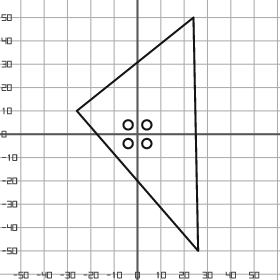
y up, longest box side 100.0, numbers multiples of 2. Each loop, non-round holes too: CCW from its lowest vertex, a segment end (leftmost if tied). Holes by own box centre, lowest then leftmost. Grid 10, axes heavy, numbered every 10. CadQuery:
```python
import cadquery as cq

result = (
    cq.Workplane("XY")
    .moveTo(26.0, -50.0)
    .lineTo(24.0, 50.0)
    .lineTo(-26.0, 10.0)
    .close()
    .moveTo(-4.0, -4.0)
    .circle(2.0)
    .moveTo(4.0, -4.0)
    .circle(2.0)
    .moveTo(-4.0, 4.0)
    .circle(2.0)
    .moveTo(4.0, 4.0)
    .circle(2.0)
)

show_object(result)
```